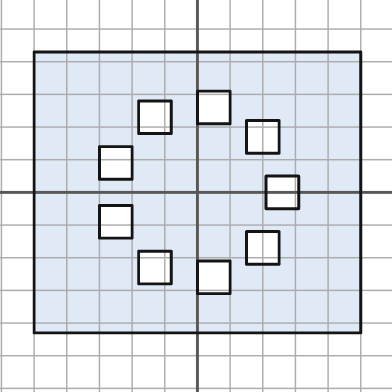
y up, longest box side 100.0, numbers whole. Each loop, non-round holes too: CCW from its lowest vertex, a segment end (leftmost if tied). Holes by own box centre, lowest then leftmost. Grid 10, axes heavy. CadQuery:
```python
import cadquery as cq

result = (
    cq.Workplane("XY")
    .moveTo(-50.0, -43.0)
    .lineTo(50.0, -43.0)
    .lineTo(50.0, 43.0)
    .lineTo(-50.0, 43.0)
    .close()
    .moveTo(0.0, -31.0)
    .lineTo(10.0, -31.0)
    .lineTo(10.0, -21.0)
    .lineTo(0.0, -21.0)
    .close()
    .moveTo(-18.0, -28.0)
    .lineTo(-8.0, -28.0)
    .lineTo(-8.0, -18.0)
    .lineTo(-18.0, -18.0)
    .close()
    .moveTo(15.0, -22.0)
    .lineTo(25.0, -22.0)
    .lineTo(25.0, -12.0)
    .lineTo(15.0, -12.0)
    .close()
    .moveTo(-30.0, -14.0)
    .lineTo(-20.0, -14.0)
    .lineTo(-20.0, -4.0)
    .lineTo(-30.0, -4.0)
    .close()
    .moveTo(21.0, -5.0)
    .lineTo(31.0, -5.0)
    .lineTo(31.0, 5.0)
    .lineTo(21.0, 5.0)
    .close()
    .moveTo(-30.0, 4.0)
    .lineTo(-20.0, 4.0)
    .lineTo(-20.0, 14.0)
    .lineTo(-30.0, 14.0)
    .close()
    .moveTo(15.0, 12.0)
    .lineTo(25.0, 12.0)
    .lineTo(25.0, 22.0)
    .lineTo(15.0, 22.0)
    .close()
    .moveTo(-18.0, 18.0)
    .lineTo(-8.0, 18.0)
    .lineTo(-8.0, 28.0)
    .lineTo(-18.0, 28.0)
    .close()
    .moveTo(0.0, 21.0)
    .lineTo(10.0, 21.0)
    .lineTo(10.0, 31.0)
    .lineTo(0.0, 31.0)
    .close()
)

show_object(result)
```